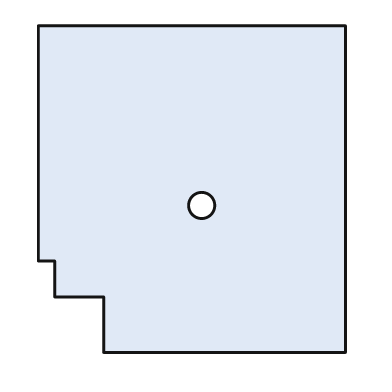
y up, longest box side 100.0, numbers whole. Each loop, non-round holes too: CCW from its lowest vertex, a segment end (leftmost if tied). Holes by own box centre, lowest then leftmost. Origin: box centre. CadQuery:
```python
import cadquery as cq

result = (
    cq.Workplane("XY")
    .moveTo(-27.0, -50.0)
    .lineTo(47.0, -50.0)
    .lineTo(47.0, 50.0)
    .lineTo(-47.0, 50.0)
    .lineTo(-47.0, -22.0)
    .lineTo(-42.0, -22.0)
    .lineTo(-42.0, -33.0)
    .lineTo(-27.0, -33.0)
    .close()
    .moveTo(3.0, -5.0)
    .circle(4.0)
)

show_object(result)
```